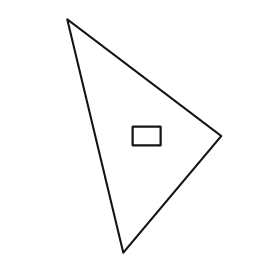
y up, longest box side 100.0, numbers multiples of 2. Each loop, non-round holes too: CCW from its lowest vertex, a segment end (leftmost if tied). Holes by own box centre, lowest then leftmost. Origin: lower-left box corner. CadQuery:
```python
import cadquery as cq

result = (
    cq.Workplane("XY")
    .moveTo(24.0, 0.0)
    .lineTo(66.0, 50.0)
    .lineTo(0.0, 100.0)
    .close()
    .moveTo(28.0, 46.0)
    .lineTo(40.0, 46.0)
    .lineTo(40.0, 54.0)
    .lineTo(28.0, 54.0)
    .close()
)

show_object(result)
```